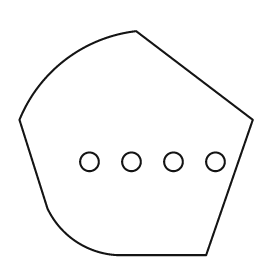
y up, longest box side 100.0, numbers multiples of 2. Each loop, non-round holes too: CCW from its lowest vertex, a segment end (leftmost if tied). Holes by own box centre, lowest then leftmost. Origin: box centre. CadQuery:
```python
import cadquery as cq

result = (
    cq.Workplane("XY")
    .moveTo(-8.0, -48.0)
    .lineTo(30.0, -48.0)
    .lineTo(50.0, 10.0)
    .lineTo(0.0, 48.0)
    .threePointArc((-30.0, 36.0), (-50.0, 10.0))
    .lineTo(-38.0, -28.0)
    .threePointArc((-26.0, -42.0), (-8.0, -48.0))
    .close()
    .moveTo(-20.0, -8.0)
    .circle(4.0)
    .moveTo(-2.0, -8.0)
    .circle(4.0)
    .moveTo(16.0, -8.0)
    .circle(4.0)
    .moveTo(34.0, -8.0)
    .circle(4.0)
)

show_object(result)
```